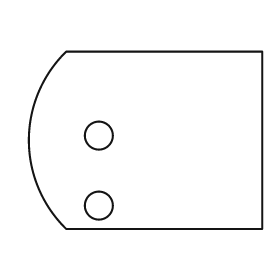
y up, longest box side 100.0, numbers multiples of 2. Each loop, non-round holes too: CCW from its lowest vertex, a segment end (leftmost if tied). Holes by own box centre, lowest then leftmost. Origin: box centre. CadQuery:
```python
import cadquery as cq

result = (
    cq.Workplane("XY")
    .moveTo(-34.0, -38.0)
    .lineTo(50.0, -38.0)
    .lineTo(50.0, 38.0)
    .lineTo(-34.0, 38.0)
    .threePointArc((-50.0, 0.0), (-34.0, -38.0))
    .close()
    .moveTo(-20.0, -28.0)
    .circle(6.0)
    .moveTo(-20.0, 2.0)
    .circle(6.0)
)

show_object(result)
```